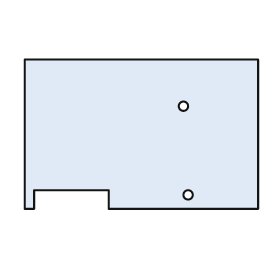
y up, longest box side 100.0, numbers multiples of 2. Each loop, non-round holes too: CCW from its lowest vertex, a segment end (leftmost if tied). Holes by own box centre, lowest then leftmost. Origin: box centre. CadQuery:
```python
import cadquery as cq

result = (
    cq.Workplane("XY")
    .moveTo(-50.0, -32.0)
    .lineTo(-46.0, -32.0)
    .lineTo(-46.0, -24.0)
    .lineTo(-14.0, -24.0)
    .lineTo(-14.0, -32.0)
    .lineTo(50.0, -32.0)
    .lineTo(50.0, 32.0)
    .lineTo(-50.0, 32.0)
    .close()
    .moveTo(20.0, -26.0)
    .circle(2.0)
    .moveTo(18.0, 12.0)
    .circle(2.0)
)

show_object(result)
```